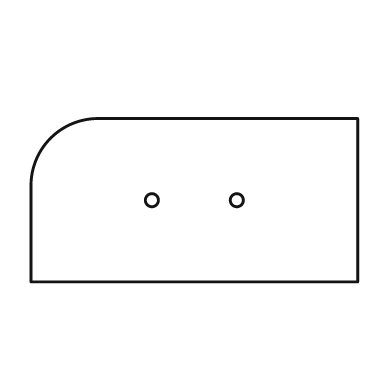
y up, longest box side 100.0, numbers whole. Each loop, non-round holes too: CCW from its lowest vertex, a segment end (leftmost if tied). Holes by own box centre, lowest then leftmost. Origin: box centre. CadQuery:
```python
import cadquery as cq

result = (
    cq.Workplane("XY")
    .moveTo(-50.0, -25.0)
    .lineTo(50.0, -25.0)
    .lineTo(50.0, 25.0)
    .lineTo(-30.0, 25.0)
    .threePointArc((-44.0, 19.0), (-50.0, 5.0))
    .close()
    .moveTo(-13.0, 0.0)
    .circle(2.0)
    .moveTo(13.0, 0.0)
    .circle(2.0)
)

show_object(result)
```